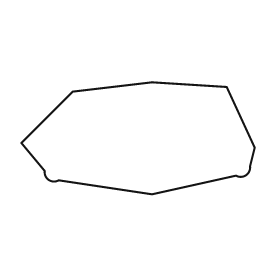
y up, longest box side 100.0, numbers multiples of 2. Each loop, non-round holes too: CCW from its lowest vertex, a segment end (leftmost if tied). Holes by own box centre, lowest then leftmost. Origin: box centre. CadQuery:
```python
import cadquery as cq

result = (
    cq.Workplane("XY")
    .moveTo(6.0, -24.0)
    .lineTo(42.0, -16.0)
    .threePointArc((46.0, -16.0), (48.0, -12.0))
    .lineTo(50.0, -4.0)
    .lineTo(38.0, 22.0)
    .lineTo(6.0, 24.0)
    .lineTo(-28.0, 20.0)
    .lineTo(-50.0, -2.0)
    .lineTo(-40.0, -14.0)
    .threePointArc((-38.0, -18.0), (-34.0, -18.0))
    .close()
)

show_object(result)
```